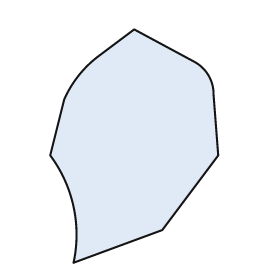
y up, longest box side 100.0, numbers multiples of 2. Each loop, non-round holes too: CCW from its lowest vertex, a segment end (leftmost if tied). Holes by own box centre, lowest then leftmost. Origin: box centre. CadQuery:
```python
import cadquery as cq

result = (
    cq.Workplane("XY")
    .moveTo(-26.0, -50.0)
    .lineTo(12.0, -36.0)
    .lineTo(36.0, -4.0)
    .lineTo(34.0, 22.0)
    .threePointArc((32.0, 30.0), (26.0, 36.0))
    .lineTo(0.0, 50.0)
    .lineTo(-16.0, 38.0)
    .threePointArc((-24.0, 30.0), (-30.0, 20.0))
    .lineTo(-36.0, -4.0)
    .threePointArc((-26.0, -26.0), (-26.0, -50.0))
    .close()
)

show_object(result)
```